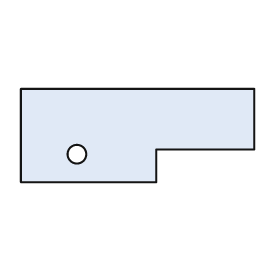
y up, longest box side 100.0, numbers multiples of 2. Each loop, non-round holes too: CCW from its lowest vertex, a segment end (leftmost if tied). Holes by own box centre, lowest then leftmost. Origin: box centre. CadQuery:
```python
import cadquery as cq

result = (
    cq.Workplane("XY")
    .moveTo(-50.0, -20.0)
    .lineTo(8.0, -20.0)
    .lineTo(8.0, -6.0)
    .lineTo(50.0, -6.0)
    .lineTo(50.0, 20.0)
    .lineTo(-50.0, 20.0)
    .close()
    .moveTo(-26.0, -8.0)
    .circle(4.0)
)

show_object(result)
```